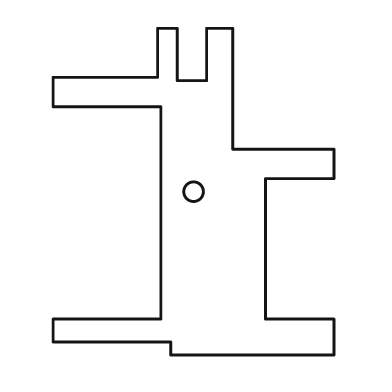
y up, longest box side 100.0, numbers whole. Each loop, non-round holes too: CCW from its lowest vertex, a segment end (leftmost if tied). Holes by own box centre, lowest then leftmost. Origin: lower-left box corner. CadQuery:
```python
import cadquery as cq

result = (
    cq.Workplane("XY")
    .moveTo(36.0, 0.0)
    .lineTo(86.0, 0.0)
    .lineTo(86.0, 11.0)
    .lineTo(65.0, 11.0)
    .lineTo(65.0, 54.0)
    .lineTo(86.0, 54.0)
    .lineTo(86.0, 63.0)
    .lineTo(55.0, 63.0)
    .lineTo(55.0, 100.0)
    .lineTo(47.0, 100.0)
    .lineTo(47.0, 84.0)
    .lineTo(38.0, 84.0)
    .lineTo(38.0, 100.0)
    .lineTo(32.0, 100.0)
    .lineTo(32.0, 85.0)
    .lineTo(0.0, 85.0)
    .lineTo(0.0, 76.0)
    .lineTo(33.0, 76.0)
    .lineTo(33.0, 11.0)
    .lineTo(0.0, 11.0)
    .lineTo(0.0, 4.0)
    .lineTo(36.0, 4.0)
    .close()
    .moveTo(43.0, 50.0)
    .circle(3.0)
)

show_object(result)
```